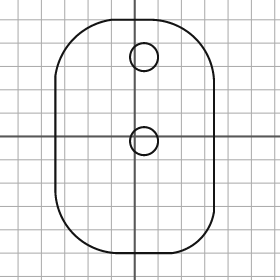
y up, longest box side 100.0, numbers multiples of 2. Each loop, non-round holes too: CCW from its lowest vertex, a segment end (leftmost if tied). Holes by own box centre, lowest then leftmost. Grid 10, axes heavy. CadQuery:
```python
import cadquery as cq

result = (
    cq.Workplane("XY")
    .moveTo(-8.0, -50.0)
    .lineTo(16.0, -50.0)
    .threePointArc((28.0, -44.0), (34.0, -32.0))
    .lineTo(34.0, 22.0)
    .threePointArc((26.0, 42.0), (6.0, 50.0))
    .lineTo(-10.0, 50.0)
    .threePointArc((-26.0, 42.0), (-34.0, 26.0))
    .lineTo(-34.0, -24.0)
    .threePointArc((-26.0, -42.0), (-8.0, -50.0))
    .close()
    .moveTo(4.0, -2.0)
    .circle(6.0)
    .moveTo(4.0, 34.0)
    .circle(6.0)
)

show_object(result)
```